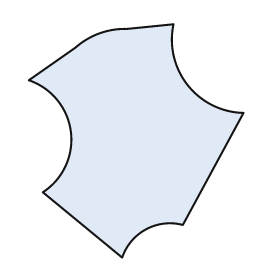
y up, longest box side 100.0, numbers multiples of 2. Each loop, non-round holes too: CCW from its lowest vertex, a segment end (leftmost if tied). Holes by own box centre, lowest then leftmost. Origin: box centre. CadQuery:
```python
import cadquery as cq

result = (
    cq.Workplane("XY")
    .moveTo(-6.0, -50.0)
    .threePointArc((4.0, -38.0), (20.0, -36.0))
    .lineTo(46.0, 12.0)
    .threePointArc((22.0, 24.0), (16.0, 50.0))
    .lineTo(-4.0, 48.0)
    .threePointArc((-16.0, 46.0), (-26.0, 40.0))
    .lineTo(-46.0, 26.0)
    .threePointArc((-28.0, 4.0), (-40.0, -22.0))
    .close()
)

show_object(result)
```